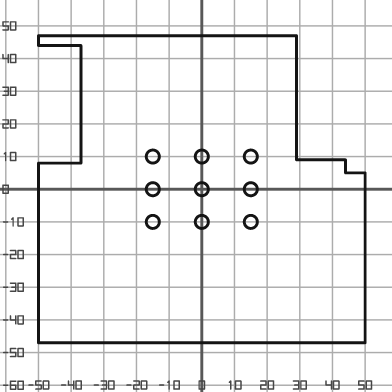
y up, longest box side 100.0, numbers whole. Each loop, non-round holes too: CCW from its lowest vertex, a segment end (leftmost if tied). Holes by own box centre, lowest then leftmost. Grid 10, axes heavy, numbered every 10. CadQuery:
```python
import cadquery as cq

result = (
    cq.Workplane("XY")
    .moveTo(-50.0, -47.0)
    .lineTo(50.0, -47.0)
    .lineTo(50.0, 5.0)
    .lineTo(44.0, 5.0)
    .lineTo(44.0, 9.0)
    .lineTo(29.0, 9.0)
    .lineTo(29.0, 47.0)
    .lineTo(-50.0, 47.0)
    .lineTo(-50.0, 44.0)
    .lineTo(-37.0, 44.0)
    .lineTo(-37.0, 8.0)
    .lineTo(-50.0, 8.0)
    .close()
    .moveTo(-15.0, -10.0)
    .circle(2.0)
    .moveTo(0.0, -10.0)
    .circle(2.0)
    .moveTo(15.0, -10.0)
    .circle(2.0)
    .moveTo(-15.0, 0.0)
    .circle(2.0)
    .moveTo(0.0, 0.0)
    .circle(2.0)
    .moveTo(15.0, 0.0)
    .circle(2.0)
    .moveTo(-15.0, 10.0)
    .circle(2.0)
    .moveTo(0.0, 10.0)
    .circle(2.0)
    .moveTo(15.0, 10.0)
    .circle(2.0)
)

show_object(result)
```